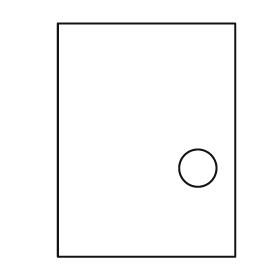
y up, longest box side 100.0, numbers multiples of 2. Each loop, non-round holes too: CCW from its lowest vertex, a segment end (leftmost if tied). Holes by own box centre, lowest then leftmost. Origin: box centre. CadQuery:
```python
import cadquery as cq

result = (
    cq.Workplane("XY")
    .moveTo(-38.0, -50.0)
    .lineTo(38.0, -50.0)
    .lineTo(38.0, 50.0)
    .lineTo(-38.0, 50.0)
    .close()
    .moveTo(22.0, -12.0)
    .circle(8.0)
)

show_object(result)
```